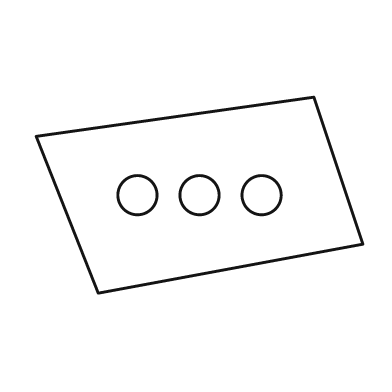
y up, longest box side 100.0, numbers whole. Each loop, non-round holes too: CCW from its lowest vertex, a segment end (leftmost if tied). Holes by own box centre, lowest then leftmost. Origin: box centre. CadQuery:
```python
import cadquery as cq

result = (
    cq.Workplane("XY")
    .moveTo(-31.0, -30.0)
    .lineTo(50.0, -15.0)
    .lineTo(35.0, 30.0)
    .lineTo(-50.0, 18.0)
    .close()
    .moveTo(-19.0, 0.0)
    .circle(6.0)
    .moveTo(0.0, 0.0)
    .circle(6.0)
    .moveTo(19.0, 0.0)
    .circle(6.0)
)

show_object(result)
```